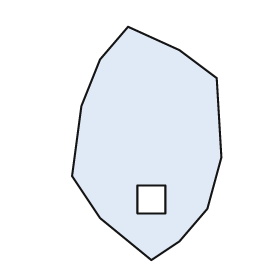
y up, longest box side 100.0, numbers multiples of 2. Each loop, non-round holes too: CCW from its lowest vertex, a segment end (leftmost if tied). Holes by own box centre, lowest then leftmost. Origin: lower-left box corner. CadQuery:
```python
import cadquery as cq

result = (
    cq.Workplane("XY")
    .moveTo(34.0, 0.0)
    .lineTo(46.0, 8.0)
    .lineTo(58.0, 22.0)
    .lineTo(64.0, 44.0)
    .lineTo(62.0, 78.0)
    .lineTo(46.0, 90.0)
    .lineTo(24.0, 100.0)
    .lineTo(12.0, 86.0)
    .lineTo(4.0, 66.0)
    .lineTo(0.0, 36.0)
    .lineTo(12.0, 18.0)
    .close()
    .moveTo(28.0, 20.0)
    .lineTo(40.0, 20.0)
    .lineTo(40.0, 32.0)
    .lineTo(28.0, 32.0)
    .close()
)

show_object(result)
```